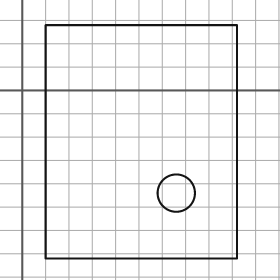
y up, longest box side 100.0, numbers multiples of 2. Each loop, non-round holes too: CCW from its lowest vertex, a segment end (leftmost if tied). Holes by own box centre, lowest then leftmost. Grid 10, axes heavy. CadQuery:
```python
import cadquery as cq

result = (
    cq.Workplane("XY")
    .moveTo(10.0, -72.0)
    .lineTo(92.0, -72.0)
    .lineTo(92.0, 28.0)
    .lineTo(10.0, 28.0)
    .close()
    .moveTo(66.0, -44.0)
    .circle(8.0)
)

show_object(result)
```